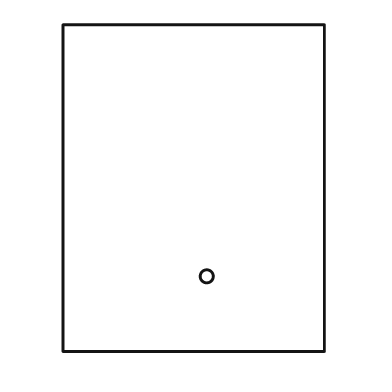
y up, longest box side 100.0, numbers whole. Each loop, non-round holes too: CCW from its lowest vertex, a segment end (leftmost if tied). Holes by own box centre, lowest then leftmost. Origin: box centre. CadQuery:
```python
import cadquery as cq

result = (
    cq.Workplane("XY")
    .moveTo(-40.0, -50.0)
    .lineTo(40.0, -50.0)
    .lineTo(40.0, 50.0)
    .lineTo(-40.0, 50.0)
    .close()
    .moveTo(4.0, -27.0)
    .circle(2.0)
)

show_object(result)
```